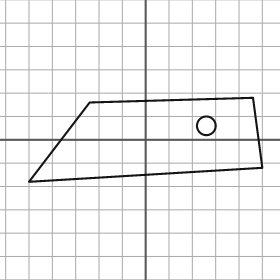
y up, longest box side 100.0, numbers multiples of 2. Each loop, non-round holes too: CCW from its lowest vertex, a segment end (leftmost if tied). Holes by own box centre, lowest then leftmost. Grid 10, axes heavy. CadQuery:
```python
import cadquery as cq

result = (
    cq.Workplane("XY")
    .moveTo(-50.0, -18.0)
    .lineTo(50.0, -12.0)
    .lineTo(46.0, 18.0)
    .lineTo(-24.0, 16.0)
    .close()
    .moveTo(26.0, 6.0)
    .circle(4.0)
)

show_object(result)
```